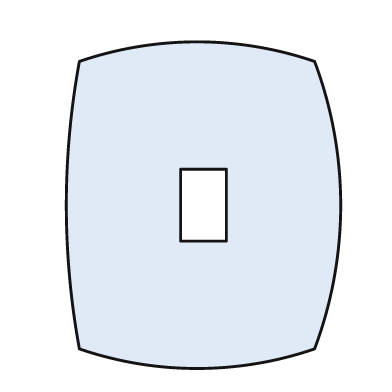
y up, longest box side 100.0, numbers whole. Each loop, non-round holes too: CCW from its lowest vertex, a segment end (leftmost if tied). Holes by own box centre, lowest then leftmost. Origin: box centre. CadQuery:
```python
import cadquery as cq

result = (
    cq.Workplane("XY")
    .moveTo(-38.0, -44.0)
    .threePointArc((-2.0, -50.0), (34.0, -44.0))
    .threePointArc((42.0, 0.0), (34.0, 44.0))
    .threePointArc((-2.0, 50.0), (-38.0, 44.0))
    .threePointArc((-42.0, 0.0), (-38.0, -44.0))
    .close()
    .moveTo(-7.0, -11.0)
    .lineTo(7.0, -11.0)
    .lineTo(7.0, 11.0)
    .lineTo(-7.0, 11.0)
    .close()
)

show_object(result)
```